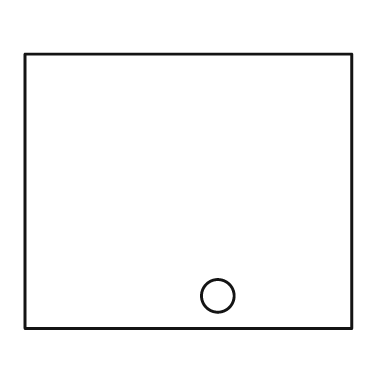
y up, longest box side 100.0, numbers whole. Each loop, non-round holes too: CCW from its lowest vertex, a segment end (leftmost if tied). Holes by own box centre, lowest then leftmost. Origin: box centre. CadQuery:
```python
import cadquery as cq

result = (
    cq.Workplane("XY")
    .moveTo(-50.0, -42.0)
    .lineTo(50.0, -42.0)
    .lineTo(50.0, 42.0)
    .lineTo(-50.0, 42.0)
    .close()
    .moveTo(9.0, -32.0)
    .circle(5.0)
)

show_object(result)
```